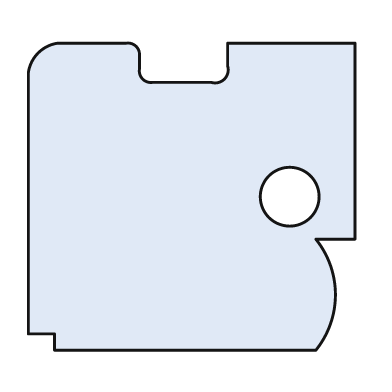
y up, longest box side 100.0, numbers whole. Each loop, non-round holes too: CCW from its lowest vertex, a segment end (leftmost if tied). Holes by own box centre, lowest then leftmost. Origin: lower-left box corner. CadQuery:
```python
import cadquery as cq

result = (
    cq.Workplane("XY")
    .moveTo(8.0, 0.0)
    .lineTo(88.0, 0.0)
    .threePointArc((94.0, 17.0), (88.0, 34.0))
    .lineTo(100.0, 34.0)
    .lineTo(100.0, 94.0)
    .lineTo(61.0, 94.0)
    .lineTo(61.0, 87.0)
    .threePointArc((60.0, 83.0), (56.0, 82.0))
    .lineTo(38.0, 82.0)
    .threePointArc((35.0, 83.0), (34.0, 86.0))
    .lineTo(34.0, 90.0)
    .threePointArc((33.0, 93.0), (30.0, 94.0))
    .lineTo(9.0, 94.0)
    .threePointArc((3.0, 91.0), (0.0, 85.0))
    .lineTo(0.0, 5.0)
    .lineTo(8.0, 5.0)
    .close()
    .moveTo(80.0, 47.0)
    .circle(9.0)
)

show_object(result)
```